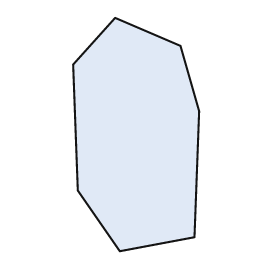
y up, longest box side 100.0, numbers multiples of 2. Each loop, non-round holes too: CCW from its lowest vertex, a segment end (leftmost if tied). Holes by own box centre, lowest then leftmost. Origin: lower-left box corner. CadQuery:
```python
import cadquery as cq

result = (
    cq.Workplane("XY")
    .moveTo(20.0, 0.0)
    .lineTo(52.0, 6.0)
    .lineTo(54.0, 60.0)
    .lineTo(46.0, 88.0)
    .lineTo(18.0, 100.0)
    .lineTo(0.0, 80.0)
    .lineTo(2.0, 26.0)
    .close()
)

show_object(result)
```